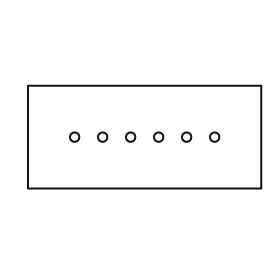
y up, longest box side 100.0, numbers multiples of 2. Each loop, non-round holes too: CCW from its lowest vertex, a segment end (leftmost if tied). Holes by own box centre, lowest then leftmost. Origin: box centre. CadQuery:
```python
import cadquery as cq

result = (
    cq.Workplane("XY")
    .moveTo(-50.0, -22.0)
    .lineTo(50.0, -22.0)
    .lineTo(50.0, 22.0)
    .lineTo(-50.0, 22.0)
    .close()
    .moveTo(-30.0, 0.0)
    .circle(2.0)
    .moveTo(-18.0, 0.0)
    .circle(2.0)
    .moveTo(-6.0, 0.0)
    .circle(2.0)
    .moveTo(6.0, 0.0)
    .circle(2.0)
    .moveTo(18.0, 0.0)
    .circle(2.0)
    .moveTo(30.0, 0.0)
    .circle(2.0)
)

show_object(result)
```